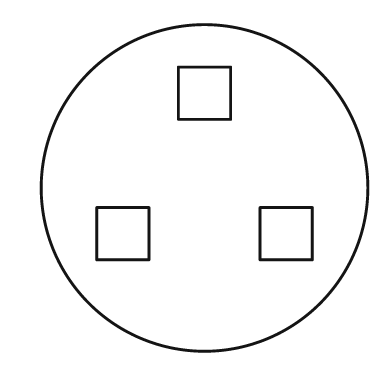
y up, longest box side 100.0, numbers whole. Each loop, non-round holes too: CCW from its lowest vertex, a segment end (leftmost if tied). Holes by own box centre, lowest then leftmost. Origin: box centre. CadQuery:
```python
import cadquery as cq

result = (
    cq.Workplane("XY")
    .moveTo(0.0, 0.0)
    .circle(50.0)
    .moveTo(-33.0, -22.0)
    .lineTo(-17.0, -22.0)
    .lineTo(-17.0, -6.0)
    .lineTo(-33.0, -6.0)
    .close()
    .moveTo(17.0, -22.0)
    .lineTo(33.0, -22.0)
    .lineTo(33.0, -6.0)
    .lineTo(17.0, -6.0)
    .close()
    .moveTo(-8.0, 21.0)
    .lineTo(8.0, 21.0)
    .lineTo(8.0, 37.0)
    .lineTo(-8.0, 37.0)
    .close()
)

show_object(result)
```